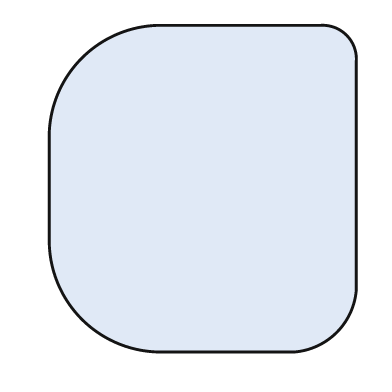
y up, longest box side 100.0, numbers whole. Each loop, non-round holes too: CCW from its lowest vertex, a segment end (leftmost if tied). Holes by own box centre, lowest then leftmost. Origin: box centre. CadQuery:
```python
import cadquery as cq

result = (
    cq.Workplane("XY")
    .moveTo(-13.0, -50.0)
    .lineTo(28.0, -50.0)
    .threePointArc((41.0, -44.0), (47.0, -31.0))
    .lineTo(47.0, 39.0)
    .threePointArc((44.0, 47.0), (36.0, 50.0))
    .lineTo(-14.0, 50.0)
    .threePointArc((-37.0, 40.0), (-47.0, 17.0))
    .lineTo(-47.0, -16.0)
    .threePointArc((-37.0, -40.0), (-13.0, -50.0))
    .close()
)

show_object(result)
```